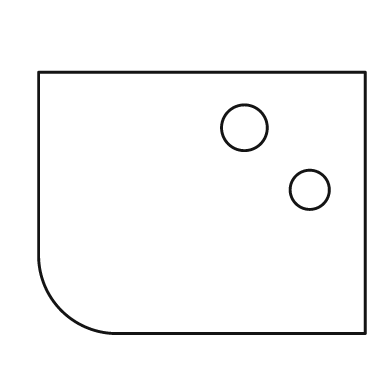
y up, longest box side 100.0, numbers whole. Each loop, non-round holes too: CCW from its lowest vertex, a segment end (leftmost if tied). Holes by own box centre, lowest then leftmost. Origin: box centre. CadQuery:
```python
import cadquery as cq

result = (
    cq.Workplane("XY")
    .moveTo(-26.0, -40.0)
    .lineTo(50.0, -40.0)
    .lineTo(50.0, 40.0)
    .lineTo(-50.0, 40.0)
    .lineTo(-50.0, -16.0)
    .threePointArc((-43.0, -33.0), (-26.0, -40.0))
    .close()
    .moveTo(33.0, 4.0)
    .circle(6.0)
    .moveTo(13.0, 23.0)
    .circle(7.0)
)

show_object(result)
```